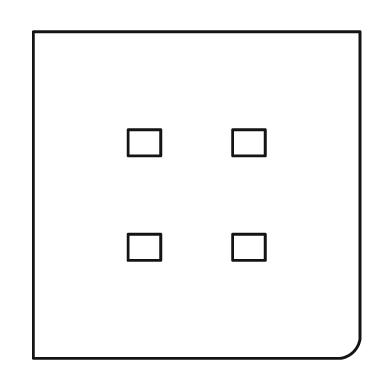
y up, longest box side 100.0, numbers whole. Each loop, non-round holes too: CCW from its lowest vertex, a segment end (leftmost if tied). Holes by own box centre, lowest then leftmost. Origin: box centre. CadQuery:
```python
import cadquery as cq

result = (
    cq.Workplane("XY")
    .moveTo(-50.0, -50.0)
    .lineTo(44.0, -50.0)
    .threePointArc((48.0, -48.0), (50.0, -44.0))
    .lineTo(50.0, 50.0)
    .lineTo(-50.0, 50.0)
    .close()
    .moveTo(-21.0, -20.0)
    .lineTo(-11.0, -20.0)
    .lineTo(-11.0, -12.0)
    .lineTo(-21.0, -12.0)
    .close()
    .moveTo(11.0, -20.0)
    .lineTo(21.0, -20.0)
    .lineTo(21.0, -12.0)
    .lineTo(11.0, -12.0)
    .close()
    .moveTo(-21.0, 12.0)
    .lineTo(-11.0, 12.0)
    .lineTo(-11.0, 20.0)
    .lineTo(-21.0, 20.0)
    .close()
    .moveTo(11.0, 12.0)
    .lineTo(21.0, 12.0)
    .lineTo(21.0, 20.0)
    .lineTo(11.0, 20.0)
    .close()
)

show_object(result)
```